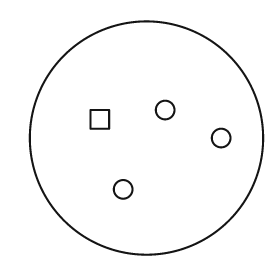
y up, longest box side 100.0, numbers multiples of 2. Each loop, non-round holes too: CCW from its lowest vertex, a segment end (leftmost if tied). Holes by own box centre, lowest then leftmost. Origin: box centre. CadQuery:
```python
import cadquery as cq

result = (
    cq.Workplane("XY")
    .moveTo(0.0, 0.0)
    .circle(50.0)
    .moveTo(-10.0, -22.0)
    .circle(4.0)
    .moveTo(32.0, 0.0)
    .circle(4.0)
    .moveTo(-24.0, 4.0)
    .lineTo(-16.0, 4.0)
    .lineTo(-16.0, 12.0)
    .lineTo(-24.0, 12.0)
    .close()
    .moveTo(8.0, 12.0)
    .circle(4.0)
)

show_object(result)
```